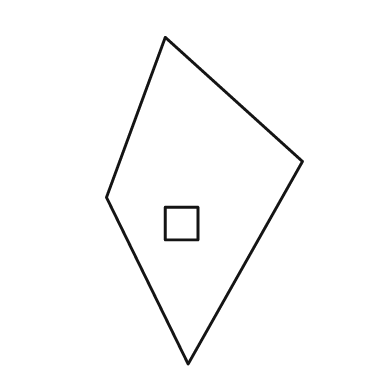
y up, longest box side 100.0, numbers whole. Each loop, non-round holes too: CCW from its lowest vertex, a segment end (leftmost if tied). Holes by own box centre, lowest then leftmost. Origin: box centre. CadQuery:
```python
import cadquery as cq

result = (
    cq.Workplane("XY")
    .moveTo(-5.0, -50.0)
    .lineTo(30.0, 12.0)
    .lineTo(-12.0, 50.0)
    .lineTo(-30.0, 1.0)
    .close()
    .moveTo(-12.0, -12.0)
    .lineTo(-2.0, -12.0)
    .lineTo(-2.0, -2.0)
    .lineTo(-12.0, -2.0)
    .close()
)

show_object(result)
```